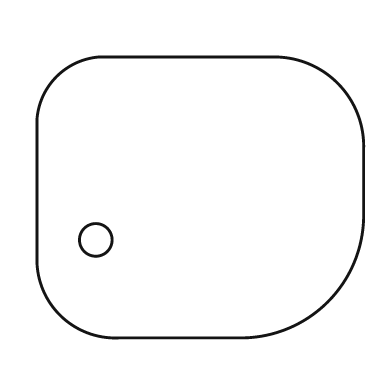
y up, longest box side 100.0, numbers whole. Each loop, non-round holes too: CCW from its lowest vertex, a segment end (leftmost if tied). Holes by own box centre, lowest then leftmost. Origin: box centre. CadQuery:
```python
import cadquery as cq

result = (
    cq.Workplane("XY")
    .moveTo(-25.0, -43.0)
    .lineTo(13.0, -43.0)
    .threePointArc((39.0, -32.0), (50.0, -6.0))
    .lineTo(50.0, 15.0)
    .threePointArc((42.0, 35.0), (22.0, 43.0))
    .lineTo(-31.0, 43.0)
    .threePointArc((-44.0, 37.0), (-50.0, 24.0))
    .lineTo(-50.0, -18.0)
    .threePointArc((-43.0, -36.0), (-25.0, -43.0))
    .close()
    .moveTo(-32.0, -13.0)
    .circle(5.0)
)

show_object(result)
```